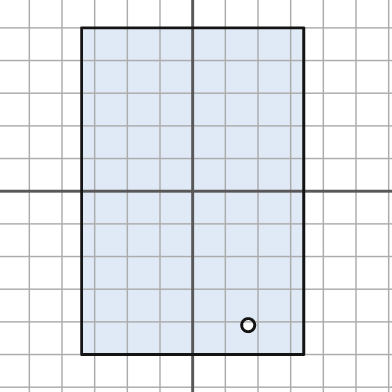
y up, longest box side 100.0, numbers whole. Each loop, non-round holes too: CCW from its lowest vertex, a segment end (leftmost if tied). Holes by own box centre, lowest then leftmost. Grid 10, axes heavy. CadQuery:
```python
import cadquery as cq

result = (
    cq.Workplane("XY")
    .moveTo(-34.0, -50.0)
    .lineTo(34.0, -50.0)
    .lineTo(34.0, 50.0)
    .lineTo(-34.0, 50.0)
    .close()
    .moveTo(17.0, -41.0)
    .circle(2.0)
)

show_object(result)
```